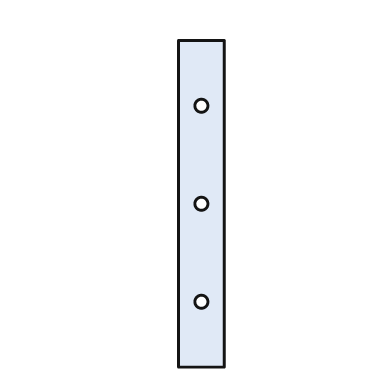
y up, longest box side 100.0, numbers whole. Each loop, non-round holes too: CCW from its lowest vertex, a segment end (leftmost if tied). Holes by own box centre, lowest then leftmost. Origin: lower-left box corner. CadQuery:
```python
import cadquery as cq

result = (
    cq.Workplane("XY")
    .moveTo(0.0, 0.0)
    .lineTo(14.0, 0.0)
    .lineTo(14.0, 100.0)
    .lineTo(0.0, 100.0)
    .close()
    .moveTo(7.0, 20.0)
    .circle(2.0)
    .moveTo(7.0, 50.0)
    .circle(2.0)
    .moveTo(7.0, 80.0)
    .circle(2.0)
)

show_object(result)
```